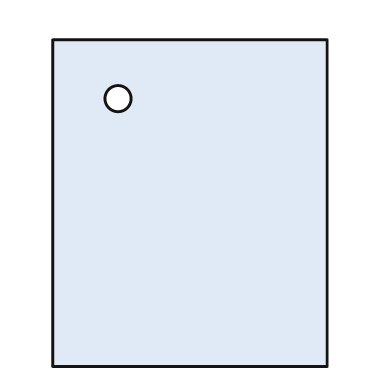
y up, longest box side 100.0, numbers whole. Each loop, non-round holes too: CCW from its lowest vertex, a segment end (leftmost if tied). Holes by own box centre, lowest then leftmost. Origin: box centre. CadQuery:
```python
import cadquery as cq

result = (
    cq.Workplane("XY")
    .moveTo(-42.0, -50.0)
    .lineTo(42.0, -50.0)
    .lineTo(42.0, 50.0)
    .lineTo(-42.0, 50.0)
    .close()
    .moveTo(-22.0, 32.0)
    .circle(4.0)
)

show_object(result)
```